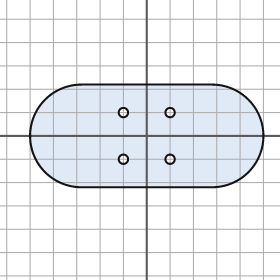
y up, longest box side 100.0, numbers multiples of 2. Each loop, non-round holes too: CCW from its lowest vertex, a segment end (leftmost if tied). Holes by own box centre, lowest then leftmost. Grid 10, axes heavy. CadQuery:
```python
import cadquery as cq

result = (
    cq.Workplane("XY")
    .moveTo(-28.0, -22.0)
    .lineTo(28.0, -22.0)
    .threePointArc((50.0, 0.0), (28.0, 22.0))
    .lineTo(-28.0, 22.0)
    .threePointArc((-50.0, 0.0), (-28.0, -22.0))
    .close()
    .moveTo(-10.0, -10.0)
    .circle(2.0)
    .moveTo(10.0, -10.0)
    .circle(2.0)
    .moveTo(-10.0, 10.0)
    .circle(2.0)
    .moveTo(10.0, 10.0)
    .circle(2.0)
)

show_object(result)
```